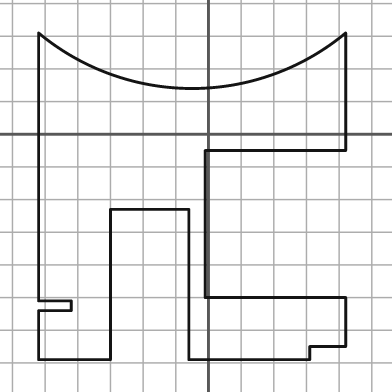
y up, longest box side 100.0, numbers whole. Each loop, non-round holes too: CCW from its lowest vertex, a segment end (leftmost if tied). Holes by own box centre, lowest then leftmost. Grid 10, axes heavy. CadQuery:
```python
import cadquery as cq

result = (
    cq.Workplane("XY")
    .moveTo(-52.0, -69.0)
    .lineTo(-30.0, -69.0)
    .lineTo(-30.0, -23.0)
    .lineTo(-6.0, -23.0)
    .lineTo(-6.0, -69.0)
    .lineTo(31.0, -69.0)
    .lineTo(31.0, -65.0)
    .lineTo(42.0, -65.0)
    .lineTo(42.0, -50.0)
    .lineTo(-1.0, -50.0)
    .lineTo(-1.0, -5.0)
    .lineTo(42.0, -5.0)
    .lineTo(42.0, 31.0)
    .threePointArc((-5.0, 14.0), (-52.0, 31.0))
    .lineTo(-52.0, -51.0)
    .lineTo(-42.0, -51.0)
    .lineTo(-42.0, -54.0)
    .lineTo(-52.0, -54.0)
    .close()
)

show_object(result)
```